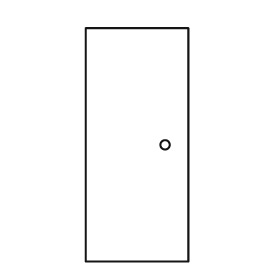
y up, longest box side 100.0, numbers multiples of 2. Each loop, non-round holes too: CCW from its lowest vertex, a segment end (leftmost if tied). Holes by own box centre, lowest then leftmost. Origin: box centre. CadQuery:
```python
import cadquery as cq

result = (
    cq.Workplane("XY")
    .moveTo(-22.0, -50.0)
    .lineTo(22.0, -50.0)
    .lineTo(22.0, 50.0)
    .lineTo(-22.0, 50.0)
    .close()
    .moveTo(12.0, 0.0)
    .circle(2.0)
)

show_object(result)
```